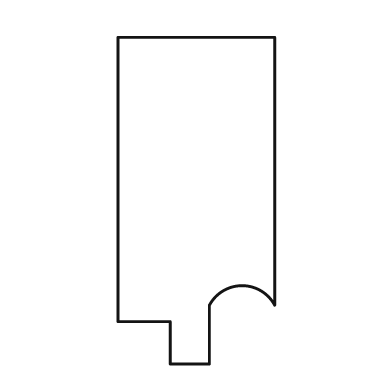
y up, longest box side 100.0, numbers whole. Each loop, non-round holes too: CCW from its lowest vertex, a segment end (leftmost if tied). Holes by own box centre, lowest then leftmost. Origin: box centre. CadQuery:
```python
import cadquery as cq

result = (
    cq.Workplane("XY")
    .moveTo(-8.0, -50.0)
    .lineTo(4.0, -50.0)
    .lineTo(4.0, -32.0)
    .threePointArc((14.0, -26.0), (24.0, -32.0))
    .lineTo(24.0, 50.0)
    .lineTo(-24.0, 50.0)
    .lineTo(-24.0, -37.0)
    .lineTo(-8.0, -37.0)
    .close()
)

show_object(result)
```